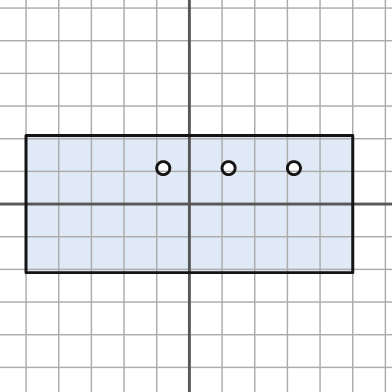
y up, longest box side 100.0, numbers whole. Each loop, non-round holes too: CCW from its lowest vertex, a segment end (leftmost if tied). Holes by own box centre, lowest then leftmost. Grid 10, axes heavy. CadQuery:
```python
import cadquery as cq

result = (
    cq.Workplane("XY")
    .moveTo(-50.0, -21.0)
    .lineTo(50.0, -21.0)
    .lineTo(50.0, 21.0)
    .lineTo(-50.0, 21.0)
    .close()
    .moveTo(-8.0, 11.0)
    .circle(2.0)
    .moveTo(12.0, 11.0)
    .circle(2.0)
    .moveTo(32.0, 11.0)
    .circle(2.0)
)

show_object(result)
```